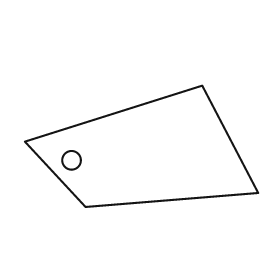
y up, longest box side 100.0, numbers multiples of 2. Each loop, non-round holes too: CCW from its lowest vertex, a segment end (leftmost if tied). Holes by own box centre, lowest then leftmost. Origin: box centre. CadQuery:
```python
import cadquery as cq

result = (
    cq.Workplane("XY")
    .moveTo(-24.0, -26.0)
    .lineTo(50.0, -20.0)
    .lineTo(26.0, 26.0)
    .lineTo(-50.0, 2.0)
    .close()
    .moveTo(-30.0, -6.0)
    .circle(4.0)
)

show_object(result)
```